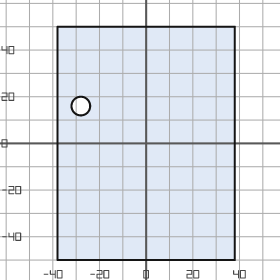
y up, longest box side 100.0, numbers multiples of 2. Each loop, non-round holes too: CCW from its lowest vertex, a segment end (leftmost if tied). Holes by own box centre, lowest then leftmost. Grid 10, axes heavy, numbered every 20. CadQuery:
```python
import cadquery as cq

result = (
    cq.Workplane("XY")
    .moveTo(-38.0, -50.0)
    .lineTo(38.0, -50.0)
    .lineTo(38.0, 50.0)
    .lineTo(-38.0, 50.0)
    .close()
    .moveTo(-28.0, 16.0)
    .circle(4.0)
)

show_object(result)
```